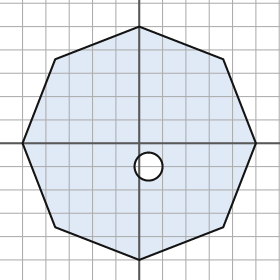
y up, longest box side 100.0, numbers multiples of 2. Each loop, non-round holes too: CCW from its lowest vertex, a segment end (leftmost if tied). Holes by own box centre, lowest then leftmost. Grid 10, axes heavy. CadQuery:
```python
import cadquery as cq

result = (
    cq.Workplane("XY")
    .moveTo(0.0, -50.0)
    .lineTo(36.0, -36.0)
    .lineTo(50.0, 0.0)
    .lineTo(36.0, 36.0)
    .lineTo(0.0, 50.0)
    .lineTo(-36.0, 36.0)
    .lineTo(-50.0, 0.0)
    .lineTo(-36.0, -36.0)
    .close()
    .moveTo(4.0, -10.0)
    .circle(6.0)
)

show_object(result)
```